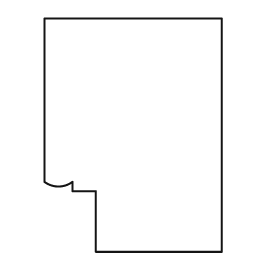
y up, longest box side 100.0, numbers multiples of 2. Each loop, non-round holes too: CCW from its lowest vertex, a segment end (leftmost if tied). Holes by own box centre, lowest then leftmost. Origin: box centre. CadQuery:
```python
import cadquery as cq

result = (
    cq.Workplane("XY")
    .moveTo(-16.0, -50.0)
    .lineTo(38.0, -50.0)
    .lineTo(38.0, 50.0)
    .lineTo(-38.0, 50.0)
    .lineTo(-38.0, -20.0)
    .threePointArc((-32.0, -22.0), (-26.0, -20.0))
    .lineTo(-26.0, -24.0)
    .lineTo(-16.0, -24.0)
    .close()
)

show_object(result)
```